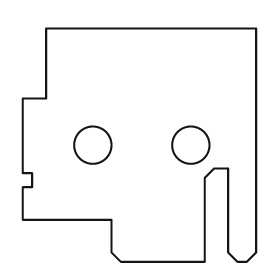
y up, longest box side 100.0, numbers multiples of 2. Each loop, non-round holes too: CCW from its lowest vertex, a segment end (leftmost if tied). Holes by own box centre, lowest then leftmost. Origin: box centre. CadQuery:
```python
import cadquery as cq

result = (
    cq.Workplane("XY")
    .moveTo(-8.0, -50.0)
    .lineTo(28.0, -50.0)
    .lineTo(28.0, -14.0)
    .lineTo(32.0, -10.0)
    .lineTo(38.0, -10.0)
    .lineTo(38.0, -46.0)
    .lineTo(42.0, -50.0)
    .lineTo(46.0, -50.0)
    .lineTo(50.0, -46.0)
    .lineTo(50.0, 50.0)
    .lineTo(-40.0, 50.0)
    .lineTo(-40.0, 20.0)
    .lineTo(-50.0, 20.0)
    .lineTo(-50.0, -12.0)
    .lineTo(-46.0, -12.0)
    .lineTo(-46.0, -18.0)
    .lineTo(-50.0, -18.0)
    .lineTo(-50.0, -32.0)
    .lineTo(-12.0, -32.0)
    .lineTo(-12.0, -46.0)
    .close()
    .moveTo(-20.0, 0.0)
    .circle(8.0)
    .moveTo(22.0, 0.0)
    .circle(8.0)
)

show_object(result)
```